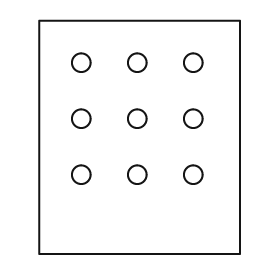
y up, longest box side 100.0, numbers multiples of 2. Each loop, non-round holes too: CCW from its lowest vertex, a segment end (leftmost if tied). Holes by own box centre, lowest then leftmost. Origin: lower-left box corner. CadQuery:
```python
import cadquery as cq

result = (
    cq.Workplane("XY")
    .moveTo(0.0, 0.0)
    .lineTo(86.0, 0.0)
    .lineTo(86.0, 100.0)
    .lineTo(0.0, 100.0)
    .close()
    .moveTo(18.0, 34.0)
    .circle(4.0)
    .moveTo(42.0, 34.0)
    .circle(4.0)
    .moveTo(66.0, 34.0)
    .circle(4.0)
    .moveTo(18.0, 58.0)
    .circle(4.0)
    .moveTo(42.0, 58.0)
    .circle(4.0)
    .moveTo(66.0, 58.0)
    .circle(4.0)
    .moveTo(18.0, 82.0)
    .circle(4.0)
    .moveTo(42.0, 82.0)
    .circle(4.0)
    .moveTo(66.0, 82.0)
    .circle(4.0)
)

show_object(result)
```